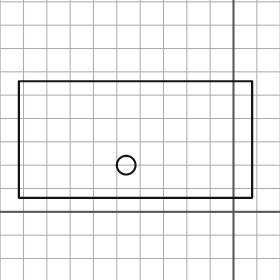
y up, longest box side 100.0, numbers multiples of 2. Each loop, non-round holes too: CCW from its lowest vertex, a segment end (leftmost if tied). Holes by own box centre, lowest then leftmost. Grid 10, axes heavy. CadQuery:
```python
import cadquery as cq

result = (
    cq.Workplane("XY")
    .moveTo(-92.0, 6.0)
    .lineTo(8.0, 6.0)
    .lineTo(8.0, 56.0)
    .lineTo(-92.0, 56.0)
    .close()
    .moveTo(-46.0, 20.0)
    .circle(4.0)
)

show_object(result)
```